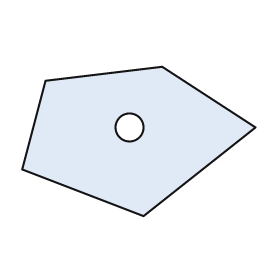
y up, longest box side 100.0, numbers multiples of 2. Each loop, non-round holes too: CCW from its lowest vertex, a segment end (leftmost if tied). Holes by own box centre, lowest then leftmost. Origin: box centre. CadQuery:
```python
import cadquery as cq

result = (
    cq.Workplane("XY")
    .moveTo(2.0, -32.0)
    .lineTo(50.0, 6.0)
    .lineTo(10.0, 32.0)
    .lineTo(-40.0, 26.0)
    .lineTo(-50.0, -12.0)
    .close()
    .moveTo(-4.0, 6.0)
    .circle(6.0)
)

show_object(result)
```